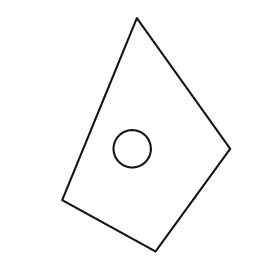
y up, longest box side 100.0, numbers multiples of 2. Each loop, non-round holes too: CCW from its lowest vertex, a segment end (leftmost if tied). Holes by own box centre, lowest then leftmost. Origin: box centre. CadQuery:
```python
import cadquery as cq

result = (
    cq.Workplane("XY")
    .moveTo(4.0, -50.0)
    .lineTo(36.0, -6.0)
    .lineTo(-4.0, 50.0)
    .lineTo(-36.0, -28.0)
    .close()
    .moveTo(-6.0, -6.0)
    .circle(8.0)
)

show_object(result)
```